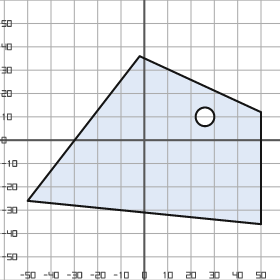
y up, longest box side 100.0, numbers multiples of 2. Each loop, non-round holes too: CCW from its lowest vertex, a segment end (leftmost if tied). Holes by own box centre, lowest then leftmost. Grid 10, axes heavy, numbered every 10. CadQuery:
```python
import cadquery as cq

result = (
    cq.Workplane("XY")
    .moveTo(50.0, -36.0)
    .lineTo(50.0, 12.0)
    .lineTo(-2.0, 36.0)
    .lineTo(-50.0, -26.0)
    .close()
    .moveTo(26.0, 10.0)
    .circle(4.0)
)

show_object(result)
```